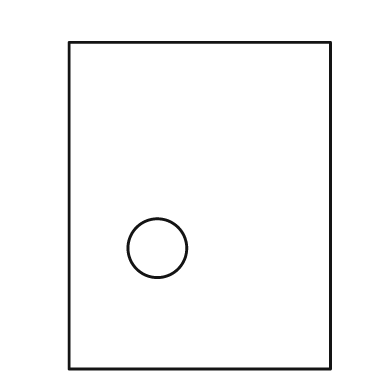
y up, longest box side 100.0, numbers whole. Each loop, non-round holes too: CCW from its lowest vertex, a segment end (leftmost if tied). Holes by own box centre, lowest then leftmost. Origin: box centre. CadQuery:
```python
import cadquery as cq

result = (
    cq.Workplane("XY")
    .moveTo(-40.0, -50.0)
    .lineTo(40.0, -50.0)
    .lineTo(40.0, 50.0)
    .lineTo(-40.0, 50.0)
    .close()
    .moveTo(-13.0, -13.0)
    .circle(9.0)
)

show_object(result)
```